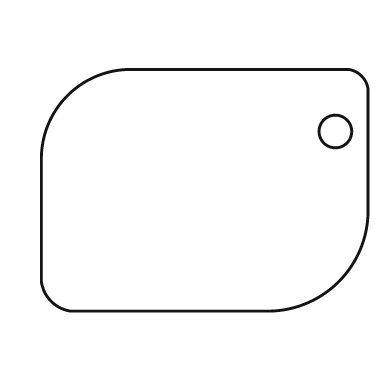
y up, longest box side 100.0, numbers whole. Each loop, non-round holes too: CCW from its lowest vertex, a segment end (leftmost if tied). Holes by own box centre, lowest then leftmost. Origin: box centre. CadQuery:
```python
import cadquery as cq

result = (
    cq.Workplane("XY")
    .moveTo(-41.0, -37.0)
    .lineTo(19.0, -37.0)
    .threePointArc((41.0, -28.0), (50.0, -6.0))
    .lineTo(50.0, 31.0)
    .threePointArc((48.0, 35.0), (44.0, 37.0))
    .lineTo(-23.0, 37.0)
    .threePointArc((-42.0, 29.0), (-50.0, 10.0))
    .lineTo(-50.0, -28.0)
    .threePointArc((-47.0, -34.0), (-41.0, -37.0))
    .close()
    .moveTo(40.0, 18.0)
    .circle(5.0)
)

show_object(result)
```